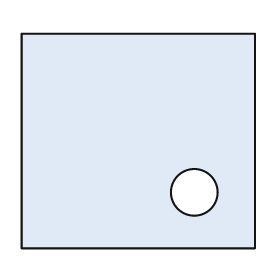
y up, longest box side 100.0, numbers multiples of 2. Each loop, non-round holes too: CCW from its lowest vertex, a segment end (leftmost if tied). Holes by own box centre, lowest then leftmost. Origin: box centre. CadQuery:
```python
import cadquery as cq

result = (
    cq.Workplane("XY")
    .moveTo(-50.0, -46.0)
    .lineTo(50.0, -46.0)
    .lineTo(50.0, 46.0)
    .lineTo(-50.0, 46.0)
    .close()
    .moveTo(24.0, -22.0)
    .circle(10.0)
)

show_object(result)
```